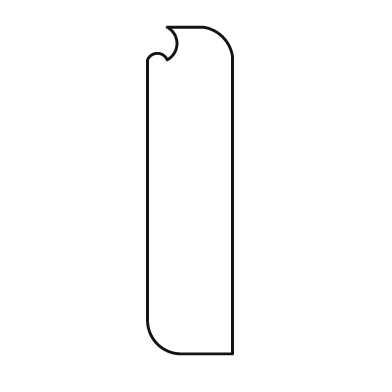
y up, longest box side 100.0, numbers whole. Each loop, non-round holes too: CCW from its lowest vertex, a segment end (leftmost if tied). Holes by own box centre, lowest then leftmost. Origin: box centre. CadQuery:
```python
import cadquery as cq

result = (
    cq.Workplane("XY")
    .moveTo(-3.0, -50.0)
    .lineTo(13.0, -50.0)
    .lineTo(13.0, 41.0)
    .threePointArc((10.0, 47.0), (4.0, 50.0))
    .lineTo(-7.0, 50.0)
    .threePointArc((-4.0, 45.0), (-7.0, 40.0))
    .threePointArc((-10.0, 42.0), (-13.0, 40.0))
    .lineTo(-13.0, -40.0)
    .threePointArc((-10.0, -47.0), (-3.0, -50.0))
    .close()
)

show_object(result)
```